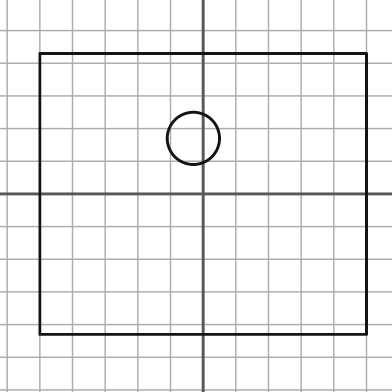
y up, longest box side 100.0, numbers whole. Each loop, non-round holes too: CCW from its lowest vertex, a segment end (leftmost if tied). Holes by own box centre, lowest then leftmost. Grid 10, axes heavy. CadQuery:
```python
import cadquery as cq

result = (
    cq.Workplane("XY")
    .moveTo(-50.0, -43.0)
    .lineTo(50.0, -43.0)
    .lineTo(50.0, 43.0)
    .lineTo(-50.0, 43.0)
    .close()
    .moveTo(-3.0, 17.0)
    .circle(8.0)
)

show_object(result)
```